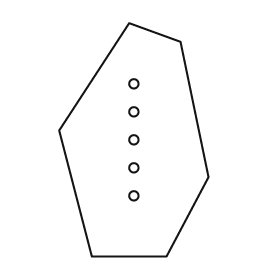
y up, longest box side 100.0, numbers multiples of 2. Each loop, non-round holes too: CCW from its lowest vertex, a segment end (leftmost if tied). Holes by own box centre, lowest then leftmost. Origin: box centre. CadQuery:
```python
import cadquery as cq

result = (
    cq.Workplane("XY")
    .moveTo(-18.0, -50.0)
    .lineTo(14.0, -50.0)
    .lineTo(32.0, -16.0)
    .lineTo(20.0, 42.0)
    .lineTo(-2.0, 50.0)
    .lineTo(-32.0, 4.0)
    .close()
    .moveTo(0.0, -24.0)
    .circle(2.0)
    .moveTo(0.0, -12.0)
    .circle(2.0)
    .moveTo(0.0, 0.0)
    .circle(2.0)
    .moveTo(0.0, 12.0)
    .circle(2.0)
    .moveTo(0.0, 24.0)
    .circle(2.0)
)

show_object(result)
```